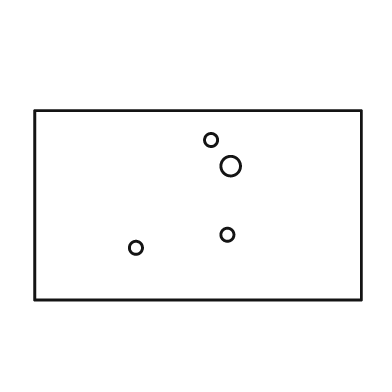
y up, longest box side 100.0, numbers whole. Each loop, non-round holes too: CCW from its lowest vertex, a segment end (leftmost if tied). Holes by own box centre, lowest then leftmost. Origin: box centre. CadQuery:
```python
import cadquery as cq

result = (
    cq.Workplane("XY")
    .moveTo(-50.0, -29.0)
    .lineTo(50.0, -29.0)
    .lineTo(50.0, 29.0)
    .lineTo(-50.0, 29.0)
    .close()
    .moveTo(-19.0, -13.0)
    .circle(2.0)
    .moveTo(9.0, -9.0)
    .circle(2.0)
    .moveTo(10.0, 12.0)
    .circle(3.0)
    .moveTo(4.0, 20.0)
    .circle(2.0)
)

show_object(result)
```